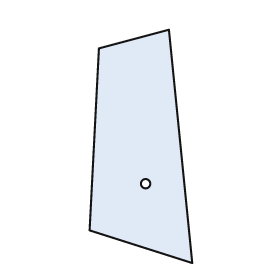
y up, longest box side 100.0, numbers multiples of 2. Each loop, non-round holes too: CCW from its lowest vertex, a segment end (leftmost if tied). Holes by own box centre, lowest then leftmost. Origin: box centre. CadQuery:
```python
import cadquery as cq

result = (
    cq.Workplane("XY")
    .moveTo(22.0, -50.0)
    .lineTo(12.0, 50.0)
    .lineTo(-18.0, 42.0)
    .lineTo(-22.0, -36.0)
    .close()
    .moveTo(2.0, -16.0)
    .circle(2.0)
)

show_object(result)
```